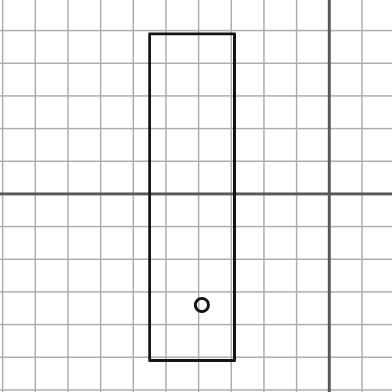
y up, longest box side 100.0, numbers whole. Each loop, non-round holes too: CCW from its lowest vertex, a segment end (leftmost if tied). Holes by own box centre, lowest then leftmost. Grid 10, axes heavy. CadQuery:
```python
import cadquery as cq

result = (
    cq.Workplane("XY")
    .moveTo(-55.0, -51.0)
    .lineTo(-29.0, -51.0)
    .lineTo(-29.0, 49.0)
    .lineTo(-55.0, 49.0)
    .close()
    .moveTo(-39.0, -34.0)
    .circle(2.0)
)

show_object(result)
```